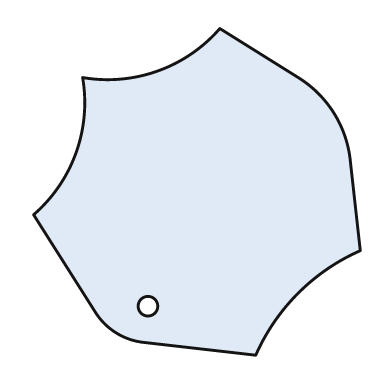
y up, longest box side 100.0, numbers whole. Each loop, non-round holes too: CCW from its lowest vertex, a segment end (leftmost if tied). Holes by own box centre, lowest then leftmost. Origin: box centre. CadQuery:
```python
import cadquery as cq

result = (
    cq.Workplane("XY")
    .moveTo(18.0, -50.0)
    .threePointArc((31.0, -31.0), (50.0, -18.0))
    .lineTo(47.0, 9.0)
    .threePointArc((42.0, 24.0), (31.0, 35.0))
    .lineTo(7.0, 50.0)
    .threePointArc((-12.0, 37.0), (-35.0, 35.0))
    .threePointArc((-37.0, 12.0), (-50.0, -7.0))
    .lineTo(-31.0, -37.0)
    .threePointArc((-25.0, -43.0), (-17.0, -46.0))
    .close()
    .moveTo(-15.0, -35.0)
    .circle(3.0)
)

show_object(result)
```